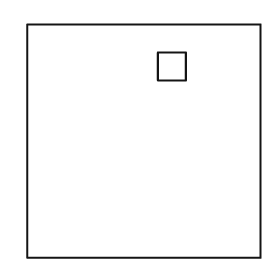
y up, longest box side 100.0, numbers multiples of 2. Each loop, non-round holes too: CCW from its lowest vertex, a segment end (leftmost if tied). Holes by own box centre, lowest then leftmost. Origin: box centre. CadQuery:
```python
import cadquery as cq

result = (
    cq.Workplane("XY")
    .moveTo(-50.0, -50.0)
    .lineTo(50.0, -50.0)
    .lineTo(50.0, 50.0)
    .lineTo(-50.0, 50.0)
    .close()
    .moveTo(6.0, 26.0)
    .lineTo(18.0, 26.0)
    .lineTo(18.0, 38.0)
    .lineTo(6.0, 38.0)
    .close()
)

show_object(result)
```